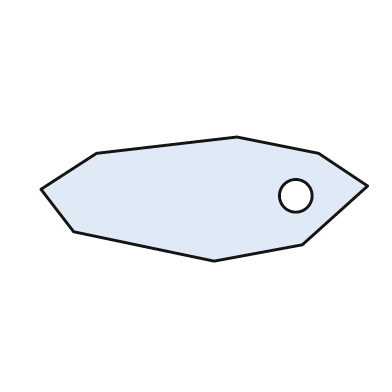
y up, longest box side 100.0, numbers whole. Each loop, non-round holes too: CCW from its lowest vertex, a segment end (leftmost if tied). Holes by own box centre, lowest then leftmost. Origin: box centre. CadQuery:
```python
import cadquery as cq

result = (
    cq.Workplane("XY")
    .moveTo(3.0, -19.0)
    .lineTo(30.0, -14.0)
    .lineTo(50.0, 4.0)
    .lineTo(35.0, 14.0)
    .lineTo(10.0, 19.0)
    .lineTo(-33.0, 14.0)
    .lineTo(-50.0, 3.0)
    .lineTo(-40.0, -10.0)
    .close()
    .moveTo(28.0, 1.0)
    .circle(5.0)
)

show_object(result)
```